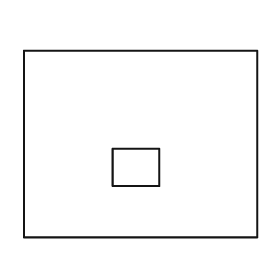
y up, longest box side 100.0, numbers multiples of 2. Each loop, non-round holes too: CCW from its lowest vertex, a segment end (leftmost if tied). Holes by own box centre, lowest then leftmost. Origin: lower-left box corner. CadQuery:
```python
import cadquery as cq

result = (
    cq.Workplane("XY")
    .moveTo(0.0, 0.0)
    .lineTo(100.0, 0.0)
    .lineTo(100.0, 80.0)
    .lineTo(0.0, 80.0)
    .close()
    .moveTo(38.0, 22.0)
    .lineTo(58.0, 22.0)
    .lineTo(58.0, 38.0)
    .lineTo(38.0, 38.0)
    .close()
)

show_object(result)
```